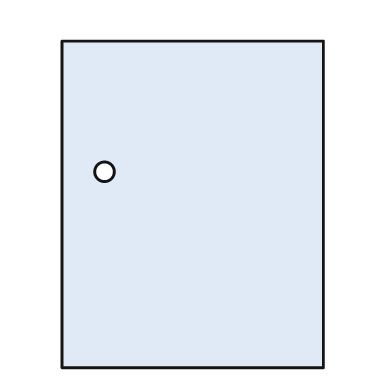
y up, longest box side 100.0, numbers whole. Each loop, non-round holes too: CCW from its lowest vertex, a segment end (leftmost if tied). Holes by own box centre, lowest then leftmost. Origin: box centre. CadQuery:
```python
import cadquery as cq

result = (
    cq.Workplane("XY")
    .moveTo(-40.0, -50.0)
    .lineTo(40.0, -50.0)
    .lineTo(40.0, 50.0)
    .lineTo(-40.0, 50.0)
    .close()
    .moveTo(-27.0, 10.0)
    .circle(3.0)
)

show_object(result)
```